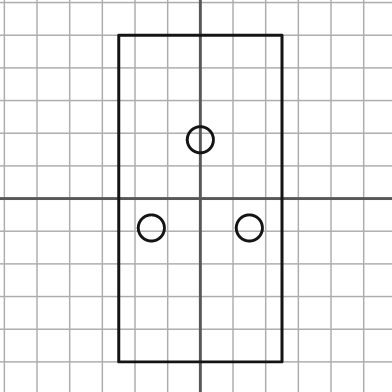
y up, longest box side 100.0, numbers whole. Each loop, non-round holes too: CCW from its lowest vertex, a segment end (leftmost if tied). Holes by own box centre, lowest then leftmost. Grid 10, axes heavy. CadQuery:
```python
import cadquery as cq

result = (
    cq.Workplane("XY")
    .moveTo(-25.0, -50.0)
    .lineTo(25.0, -50.0)
    .lineTo(25.0, 50.0)
    .lineTo(-25.0, 50.0)
    .close()
    .moveTo(-15.0, -9.0)
    .circle(4.0)
    .moveTo(15.0, -9.0)
    .circle(4.0)
    .moveTo(0.0, 18.0)
    .circle(4.0)
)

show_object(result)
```